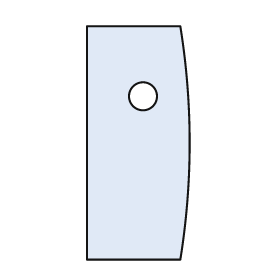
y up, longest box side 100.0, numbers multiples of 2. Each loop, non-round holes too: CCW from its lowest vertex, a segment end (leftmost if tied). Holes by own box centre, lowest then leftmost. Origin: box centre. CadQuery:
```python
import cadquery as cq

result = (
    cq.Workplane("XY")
    .moveTo(-22.0, -50.0)
    .lineTo(18.0, -50.0)
    .threePointArc((22.0, 0.0), (18.0, 50.0))
    .lineTo(-22.0, 50.0)
    .close()
    .moveTo(2.0, 20.0)
    .circle(6.0)
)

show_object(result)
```